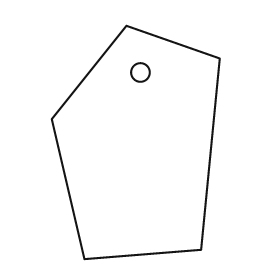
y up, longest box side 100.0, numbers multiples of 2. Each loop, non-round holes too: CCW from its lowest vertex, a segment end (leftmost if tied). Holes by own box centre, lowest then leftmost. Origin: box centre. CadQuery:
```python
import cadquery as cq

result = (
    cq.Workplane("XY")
    .moveTo(-22.0, -50.0)
    .lineTo(28.0, -46.0)
    .lineTo(36.0, 36.0)
    .lineTo(-4.0, 50.0)
    .lineTo(-36.0, 10.0)
    .close()
    .moveTo(2.0, 30.0)
    .circle(4.0)
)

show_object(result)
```